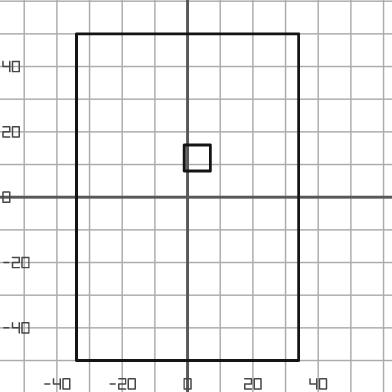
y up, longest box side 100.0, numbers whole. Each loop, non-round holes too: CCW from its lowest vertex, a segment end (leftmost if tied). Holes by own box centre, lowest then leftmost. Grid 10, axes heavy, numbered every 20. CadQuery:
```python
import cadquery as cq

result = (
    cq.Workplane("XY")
    .moveTo(-34.0, -50.0)
    .lineTo(34.0, -50.0)
    .lineTo(34.0, 50.0)
    .lineTo(-34.0, 50.0)
    .close()
    .moveTo(-1.0, 8.0)
    .lineTo(7.0, 8.0)
    .lineTo(7.0, 16.0)
    .lineTo(-1.0, 16.0)
    .close()
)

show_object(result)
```